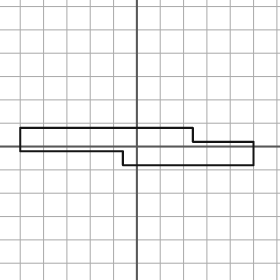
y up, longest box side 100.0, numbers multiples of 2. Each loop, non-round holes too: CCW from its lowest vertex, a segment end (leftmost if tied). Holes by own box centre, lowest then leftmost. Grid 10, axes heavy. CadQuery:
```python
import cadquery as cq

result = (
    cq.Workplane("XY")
    .moveTo(-6.0, -8.0)
    .lineTo(50.0, -8.0)
    .lineTo(50.0, 2.0)
    .lineTo(24.0, 2.0)
    .lineTo(24.0, 8.0)
    .lineTo(-50.0, 8.0)
    .lineTo(-50.0, -2.0)
    .lineTo(-6.0, -2.0)
    .close()
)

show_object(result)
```